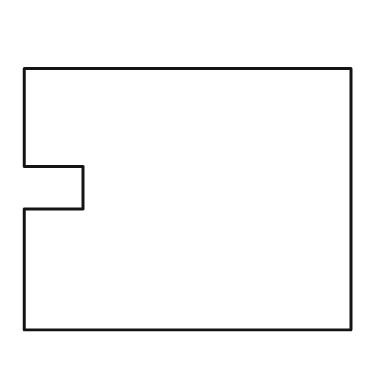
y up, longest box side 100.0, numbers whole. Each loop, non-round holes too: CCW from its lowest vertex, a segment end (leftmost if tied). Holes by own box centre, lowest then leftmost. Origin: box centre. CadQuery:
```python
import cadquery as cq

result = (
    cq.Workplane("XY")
    .moveTo(-50.0, -40.0)
    .lineTo(50.0, -40.0)
    .lineTo(50.0, 40.0)
    .lineTo(-50.0, 40.0)
    .lineTo(-50.0, 10.0)
    .lineTo(-32.0, 10.0)
    .lineTo(-32.0, -3.0)
    .lineTo(-50.0, -3.0)
    .close()
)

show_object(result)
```